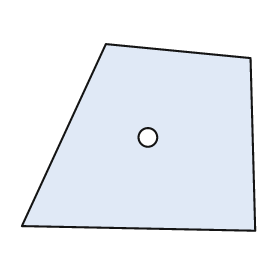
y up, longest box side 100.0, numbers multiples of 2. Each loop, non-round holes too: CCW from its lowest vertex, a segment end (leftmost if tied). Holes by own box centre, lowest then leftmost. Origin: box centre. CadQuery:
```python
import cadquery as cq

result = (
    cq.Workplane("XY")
    .moveTo(50.0, -40.0)
    .lineTo(48.0, 34.0)
    .lineTo(-14.0, 40.0)
    .lineTo(-50.0, -38.0)
    .close()
    .moveTo(4.0, 0.0)
    .circle(4.0)
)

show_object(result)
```